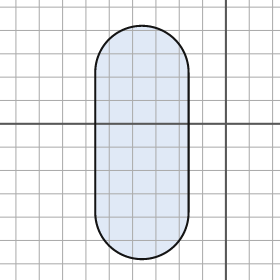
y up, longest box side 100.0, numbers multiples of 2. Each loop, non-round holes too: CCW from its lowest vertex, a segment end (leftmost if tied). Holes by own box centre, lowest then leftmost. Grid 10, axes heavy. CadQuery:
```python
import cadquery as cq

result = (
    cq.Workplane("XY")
    .moveTo(-56.0, -38.0)
    .threePointArc((-36.0, -58.0), (-16.0, -38.0))
    .lineTo(-16.0, 22.0)
    .threePointArc((-36.0, 42.0), (-56.0, 22.0))
    .close()
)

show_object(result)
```